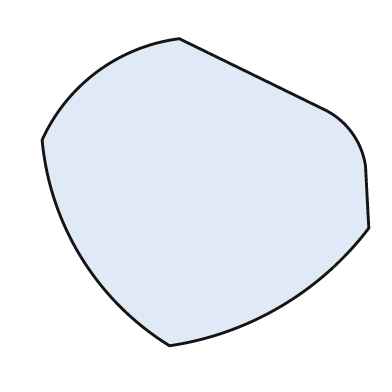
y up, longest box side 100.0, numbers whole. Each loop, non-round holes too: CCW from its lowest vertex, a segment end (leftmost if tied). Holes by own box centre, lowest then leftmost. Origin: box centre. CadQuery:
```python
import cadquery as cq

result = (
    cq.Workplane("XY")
    .moveTo(-11.0, -47.0)
    .threePointArc((23.0, -35.0), (50.0, -11.0))
    .lineTo(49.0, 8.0)
    .threePointArc((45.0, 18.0), (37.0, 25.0))
    .lineTo(-8.0, 47.0)
    .threePointArc((-33.0, 37.0), (-50.0, 16.0))
    .threePointArc((-38.0, -20.0), (-11.0, -47.0))
    .close()
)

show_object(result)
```